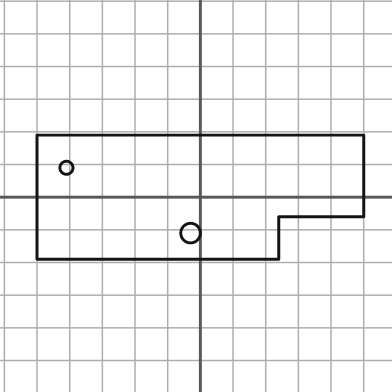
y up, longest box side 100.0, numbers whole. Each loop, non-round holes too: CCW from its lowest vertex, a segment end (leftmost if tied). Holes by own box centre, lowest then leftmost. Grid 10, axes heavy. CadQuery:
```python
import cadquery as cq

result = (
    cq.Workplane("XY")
    .moveTo(-50.0, -19.0)
    .lineTo(24.0, -19.0)
    .lineTo(24.0, -6.0)
    .lineTo(50.0, -6.0)
    .lineTo(50.0, 19.0)
    .lineTo(-50.0, 19.0)
    .close()
    .moveTo(-3.0, -11.0)
    .circle(3.0)
    .moveTo(-41.0, 9.0)
    .circle(2.0)
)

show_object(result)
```